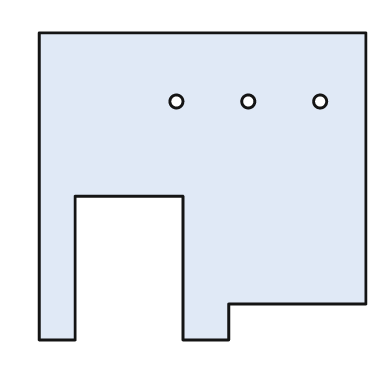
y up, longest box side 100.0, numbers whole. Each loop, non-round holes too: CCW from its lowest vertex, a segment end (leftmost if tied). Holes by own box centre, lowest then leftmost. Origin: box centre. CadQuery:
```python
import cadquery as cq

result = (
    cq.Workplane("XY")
    .moveTo(-50.0, -47.0)
    .lineTo(-39.0, -47.0)
    .lineTo(-39.0, -3.0)
    .lineTo(-6.0, -3.0)
    .lineTo(-6.0, -47.0)
    .lineTo(8.0, -47.0)
    .lineTo(8.0, -36.0)
    .lineTo(50.0, -36.0)
    .lineTo(50.0, 47.0)
    .lineTo(-50.0, 47.0)
    .close()
    .moveTo(-8.0, 26.0)
    .circle(2.0)
    .moveTo(14.0, 26.0)
    .circle(2.0)
    .moveTo(36.0, 26.0)
    .circle(2.0)
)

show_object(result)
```